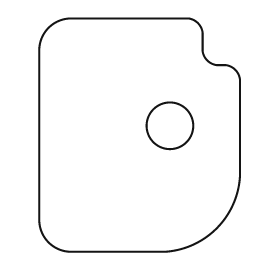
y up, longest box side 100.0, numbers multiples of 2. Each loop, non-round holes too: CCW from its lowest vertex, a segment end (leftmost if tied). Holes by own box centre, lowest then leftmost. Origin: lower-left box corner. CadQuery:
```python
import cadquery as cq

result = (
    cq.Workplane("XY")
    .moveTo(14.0, 0.0)
    .lineTo(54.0, 0.0)
    .threePointArc((76.0, 10.0), (86.0, 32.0))
    .lineTo(86.0, 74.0)
    .threePointArc((84.0, 78.0), (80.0, 80.0))
    .lineTo(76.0, 80.0)
    .threePointArc((72.0, 82.0), (70.0, 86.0))
    .lineTo(70.0, 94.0)
    .threePointArc((68.0, 98.0), (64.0, 100.0))
    .lineTo(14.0, 100.0)
    .threePointArc((4.0, 96.0), (0.0, 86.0))
    .lineTo(0.0, 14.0)
    .threePointArc((4.0, 4.0), (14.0, 0.0))
    .close()
    .moveTo(56.0, 54.0)
    .circle(10.0)
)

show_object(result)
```